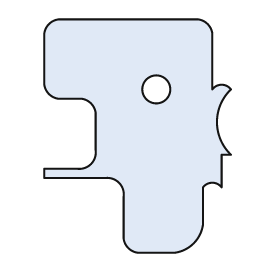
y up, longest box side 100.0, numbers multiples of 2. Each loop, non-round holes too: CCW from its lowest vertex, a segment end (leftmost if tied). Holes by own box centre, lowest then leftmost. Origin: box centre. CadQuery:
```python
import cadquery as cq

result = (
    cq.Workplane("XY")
    .moveTo(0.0, -50.0)
    .lineTo(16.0, -50.0)
    .threePointArc((24.0, -46.0), (28.0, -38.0))
    .lineTo(28.0, -22.0)
    .threePointArc((32.0, -20.0), (36.0, -22.0))
    .lineTo(36.0, -8.0)
    .lineTo(40.0, -8.0)
    .threePointArc((34.0, 6.0), (40.0, 20.0))
    .threePointArc((36.0, 22.0), (32.0, 20.0))
    .lineTo(32.0, 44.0)
    .threePointArc((30.0, 48.0), (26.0, 50.0))
    .lineTo(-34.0, 50.0)
    .threePointArc((-38.0, 48.0), (-40.0, 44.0))
    .lineTo(-40.0, 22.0)
    .threePointArc((-38.0, 18.0), (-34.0, 16.0))
    .lineTo(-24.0, 16.0)
    .threePointArc((-20.0, 14.0), (-18.0, 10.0))
    .lineTo(-18.0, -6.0)
    .threePointArc((-20.0, -12.0), (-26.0, -14.0))
    .lineTo(-40.0, -14.0)
    .lineTo(-40.0, -18.0)
    .lineTo(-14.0, -18.0)
    .threePointArc((-8.0, -20.0), (-6.0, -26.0))
    .lineTo(-6.0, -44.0)
    .threePointArc((-4.0, -48.0), (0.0, -50.0))
    .close()
    .moveTo(8.0, 20.0)
    .circle(6.0)
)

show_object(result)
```